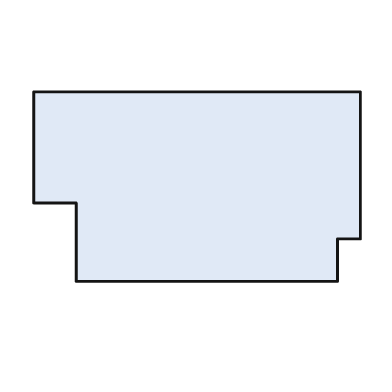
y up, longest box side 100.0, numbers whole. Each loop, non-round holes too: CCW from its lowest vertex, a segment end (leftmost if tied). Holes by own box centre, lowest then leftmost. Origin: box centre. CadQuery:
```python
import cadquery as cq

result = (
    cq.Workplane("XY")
    .moveTo(-37.0, -29.0)
    .lineTo(43.0, -29.0)
    .lineTo(43.0, -16.0)
    .lineTo(50.0, -16.0)
    .lineTo(50.0, 29.0)
    .lineTo(-50.0, 29.0)
    .lineTo(-50.0, -5.0)
    .lineTo(-37.0, -5.0)
    .close()
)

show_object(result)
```